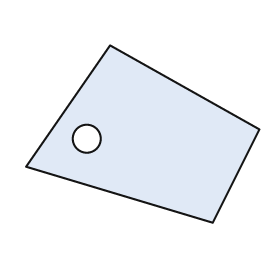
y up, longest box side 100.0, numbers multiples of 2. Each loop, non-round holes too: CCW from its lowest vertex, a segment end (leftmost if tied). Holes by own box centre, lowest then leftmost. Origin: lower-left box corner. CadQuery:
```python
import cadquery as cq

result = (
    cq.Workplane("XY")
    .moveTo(80.0, 0.0)
    .lineTo(100.0, 40.0)
    .lineTo(36.0, 76.0)
    .lineTo(0.0, 24.0)
    .close()
    .moveTo(26.0, 36.0)
    .circle(6.0)
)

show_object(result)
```